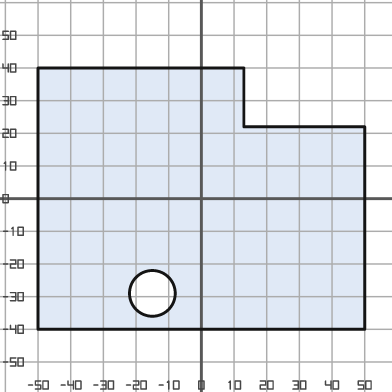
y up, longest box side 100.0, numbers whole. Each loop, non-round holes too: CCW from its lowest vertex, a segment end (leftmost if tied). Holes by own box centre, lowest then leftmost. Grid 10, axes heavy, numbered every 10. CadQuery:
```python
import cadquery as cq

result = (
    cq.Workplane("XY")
    .moveTo(-50.0, -40.0)
    .lineTo(50.0, -40.0)
    .lineTo(50.0, 22.0)
    .lineTo(13.0, 22.0)
    .lineTo(13.0, 40.0)
    .lineTo(-50.0, 40.0)
    .close()
    .moveTo(-15.0, -29.0)
    .circle(7.0)
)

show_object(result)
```